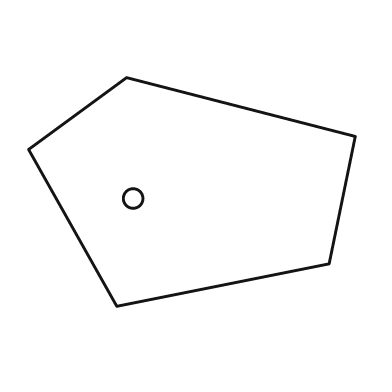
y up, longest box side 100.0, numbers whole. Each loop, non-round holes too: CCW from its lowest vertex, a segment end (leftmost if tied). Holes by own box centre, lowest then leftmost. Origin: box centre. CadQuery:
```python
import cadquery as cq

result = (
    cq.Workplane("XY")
    .moveTo(-23.0, -35.0)
    .lineTo(42.0, -22.0)
    .lineTo(50.0, 17.0)
    .lineTo(-20.0, 35.0)
    .lineTo(-50.0, 13.0)
    .close()
    .moveTo(-18.0, -2.0)
    .circle(3.0)
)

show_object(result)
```